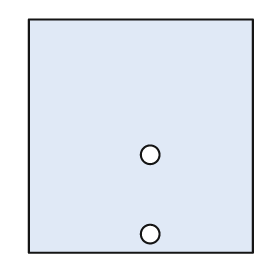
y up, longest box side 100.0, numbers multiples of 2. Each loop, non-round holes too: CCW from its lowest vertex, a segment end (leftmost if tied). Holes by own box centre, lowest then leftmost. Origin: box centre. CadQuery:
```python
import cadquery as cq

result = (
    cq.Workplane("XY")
    .moveTo(-48.0, -50.0)
    .lineTo(48.0, -50.0)
    .lineTo(48.0, 50.0)
    .lineTo(-48.0, 50.0)
    .close()
    .moveTo(4.0, -42.0)
    .circle(4.0)
    .moveTo(4.0, -8.0)
    .circle(4.0)
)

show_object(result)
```